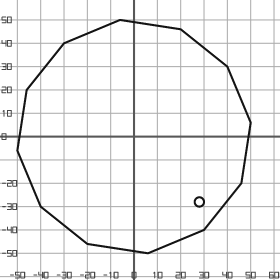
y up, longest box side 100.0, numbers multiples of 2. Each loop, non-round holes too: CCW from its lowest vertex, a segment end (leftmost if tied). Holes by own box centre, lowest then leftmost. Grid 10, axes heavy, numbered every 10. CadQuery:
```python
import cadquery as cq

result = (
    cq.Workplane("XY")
    .moveTo(6.0, -50.0)
    .lineTo(30.0, -40.0)
    .lineTo(46.0, -20.0)
    .lineTo(50.0, 6.0)
    .lineTo(40.0, 30.0)
    .lineTo(20.0, 46.0)
    .lineTo(-6.0, 50.0)
    .lineTo(-30.0, 40.0)
    .lineTo(-46.0, 20.0)
    .lineTo(-50.0, -6.0)
    .lineTo(-40.0, -30.0)
    .lineTo(-20.0, -46.0)
    .close()
    .moveTo(28.0, -28.0)
    .circle(2.0)
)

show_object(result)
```